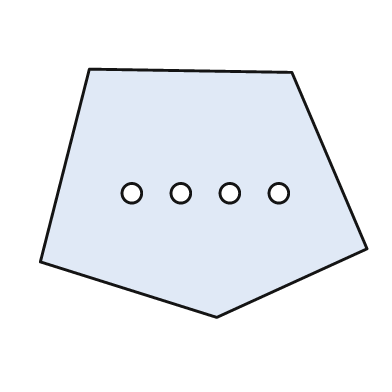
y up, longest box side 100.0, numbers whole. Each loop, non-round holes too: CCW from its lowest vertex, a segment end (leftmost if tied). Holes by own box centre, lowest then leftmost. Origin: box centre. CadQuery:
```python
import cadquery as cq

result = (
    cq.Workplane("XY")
    .moveTo(4.0, -38.0)
    .lineTo(50.0, -17.0)
    .lineTo(27.0, 37.0)
    .lineTo(-35.0, 38.0)
    .lineTo(-50.0, -21.0)
    .close()
    .moveTo(-22.0, 0.0)
    .circle(3.0)
    .moveTo(-7.0, 0.0)
    .circle(3.0)
    .moveTo(8.0, 0.0)
    .circle(3.0)
    .moveTo(23.0, 0.0)
    .circle(3.0)
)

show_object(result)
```